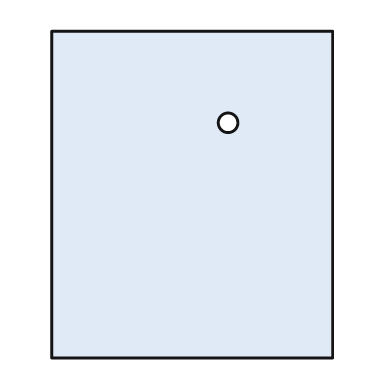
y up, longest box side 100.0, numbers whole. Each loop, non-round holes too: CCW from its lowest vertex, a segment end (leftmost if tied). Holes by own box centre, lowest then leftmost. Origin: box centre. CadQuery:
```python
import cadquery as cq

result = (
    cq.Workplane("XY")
    .moveTo(-43.0, -50.0)
    .lineTo(43.0, -50.0)
    .lineTo(43.0, 50.0)
    .lineTo(-43.0, 50.0)
    .close()
    .moveTo(11.0, 22.0)
    .circle(3.0)
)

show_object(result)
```